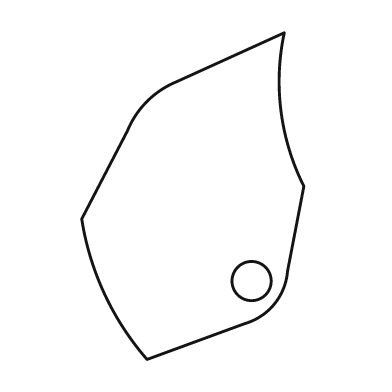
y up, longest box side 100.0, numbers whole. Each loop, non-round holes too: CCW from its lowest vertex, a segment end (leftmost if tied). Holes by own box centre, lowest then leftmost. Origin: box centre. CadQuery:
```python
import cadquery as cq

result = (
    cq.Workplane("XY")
    .moveTo(-14.0, -50.0)
    .lineTo(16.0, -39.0)
    .threePointArc((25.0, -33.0), (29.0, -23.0))
    .lineTo(34.0, 3.0)
    .threePointArc((27.0, 26.0), (28.0, 50.0))
    .lineTo(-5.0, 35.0)
    .threePointArc((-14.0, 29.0), (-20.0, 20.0))
    .lineTo(-34.0, -7.0)
    .threePointArc((-27.0, -30.0), (-14.0, -50.0))
    .close()
    .moveTo(18.0, -26.0)
    .circle(6.0)
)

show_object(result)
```